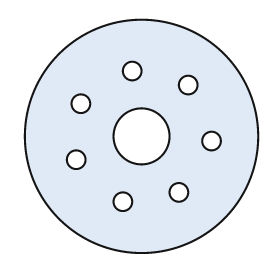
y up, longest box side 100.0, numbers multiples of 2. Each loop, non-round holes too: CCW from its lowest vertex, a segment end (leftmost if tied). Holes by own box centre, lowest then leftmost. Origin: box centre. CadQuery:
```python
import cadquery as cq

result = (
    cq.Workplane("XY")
    .moveTo(0.0, 0.0)
    .circle(50.0)
    .moveTo(-8.0, -28.0)
    .circle(4.0)
    .moveTo(16.0, -24.0)
    .circle(4.0)
    .moveTo(-28.0, -10.0)
    .circle(4.0)
    .moveTo(30.0, -2.0)
    .circle(4.0)
    .moveTo(0.0, 0.0)
    .circle(12.0)
    .moveTo(-26.0, 14.0)
    .circle(4.0)
    .moveTo(20.0, 22.0)
    .circle(4.0)
    .moveTo(-4.0, 28.0)
    .circle(4.0)
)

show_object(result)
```